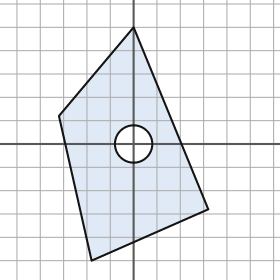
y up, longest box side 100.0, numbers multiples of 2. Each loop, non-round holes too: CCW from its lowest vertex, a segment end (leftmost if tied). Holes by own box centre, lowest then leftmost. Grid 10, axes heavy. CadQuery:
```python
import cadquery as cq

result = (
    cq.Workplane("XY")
    .moveTo(-18.0, -50.0)
    .lineTo(32.0, -28.0)
    .lineTo(0.0, 50.0)
    .lineTo(-32.0, 12.0)
    .close()
    .moveTo(0.0, 0.0)
    .circle(8.0)
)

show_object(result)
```